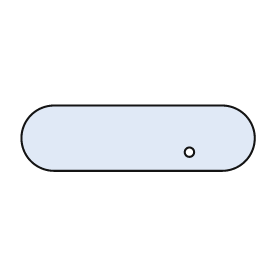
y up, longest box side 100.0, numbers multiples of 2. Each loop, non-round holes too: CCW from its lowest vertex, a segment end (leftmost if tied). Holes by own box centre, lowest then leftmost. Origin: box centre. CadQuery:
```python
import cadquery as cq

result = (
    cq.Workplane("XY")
    .moveTo(-36.0, -14.0)
    .lineTo(36.0, -14.0)
    .threePointArc((50.0, 0.0), (36.0, 14.0))
    .lineTo(-36.0, 14.0)
    .threePointArc((-50.0, 0.0), (-36.0, -14.0))
    .close()
    .moveTo(22.0, -6.0)
    .circle(2.0)
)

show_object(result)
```